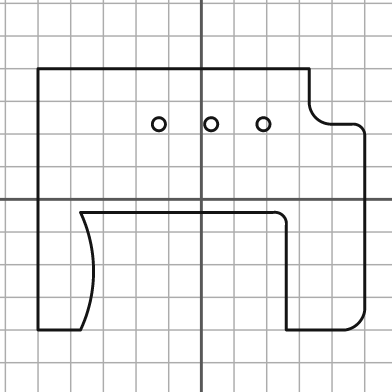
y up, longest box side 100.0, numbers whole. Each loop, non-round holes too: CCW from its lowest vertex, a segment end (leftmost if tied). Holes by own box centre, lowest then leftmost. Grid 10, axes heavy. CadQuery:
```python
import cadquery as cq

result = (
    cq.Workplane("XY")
    .moveTo(-50.0, -40.0)
    .lineTo(-37.0, -40.0)
    .threePointArc((-33.0, -22.0), (-37.0, -4.0))
    .lineTo(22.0, -4.0)
    .threePointArc((25.0, -5.0), (26.0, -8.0))
    .lineTo(26.0, -40.0)
    .lineTo(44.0, -40.0)
    .threePointArc((48.0, -38.0), (50.0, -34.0))
    .lineTo(50.0, 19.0)
    .threePointArc((49.0, 22.0), (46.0, 23.0))
    .lineTo(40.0, 23.0)
    .threePointArc((35.0, 25.0), (33.0, 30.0))
    .lineTo(33.0, 40.0)
    .lineTo(-50.0, 40.0)
    .close()
    .moveTo(-13.0, 23.0)
    .circle(2.0)
    .moveTo(3.0, 23.0)
    .circle(2.0)
    .moveTo(19.0, 23.0)
    .circle(2.0)
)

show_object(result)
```